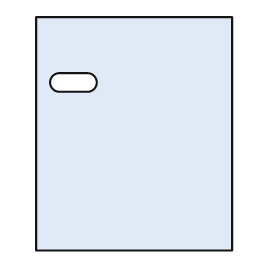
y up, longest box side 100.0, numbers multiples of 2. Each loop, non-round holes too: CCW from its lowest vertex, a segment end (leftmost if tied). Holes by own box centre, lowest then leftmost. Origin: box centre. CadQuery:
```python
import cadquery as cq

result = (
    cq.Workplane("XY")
    .moveTo(-42.0, -50.0)
    .lineTo(42.0, -50.0)
    .lineTo(42.0, 50.0)
    .lineTo(-42.0, 50.0)
    .close()
    .moveTo(-32.0, 18.0)
    .lineTo(-20.0, 18.0)
    .threePointArc((-16.0, 22.0), (-20.0, 26.0))
    .lineTo(-32.0, 26.0)
    .threePointArc((-36.0, 22.0), (-32.0, 18.0))
    .close()
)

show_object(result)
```